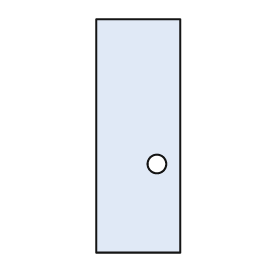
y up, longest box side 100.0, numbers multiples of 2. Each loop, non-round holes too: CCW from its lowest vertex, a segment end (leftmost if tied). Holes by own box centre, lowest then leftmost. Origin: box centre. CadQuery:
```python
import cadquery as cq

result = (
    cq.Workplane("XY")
    .moveTo(-18.0, -50.0)
    .lineTo(18.0, -50.0)
    .lineTo(18.0, 50.0)
    .lineTo(-18.0, 50.0)
    .close()
    .moveTo(8.0, -12.0)
    .circle(4.0)
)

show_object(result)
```